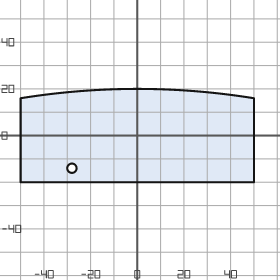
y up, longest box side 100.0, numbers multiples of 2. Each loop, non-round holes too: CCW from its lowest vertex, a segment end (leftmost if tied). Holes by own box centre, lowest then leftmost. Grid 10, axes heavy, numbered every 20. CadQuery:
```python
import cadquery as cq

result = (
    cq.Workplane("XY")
    .moveTo(-50.0, -20.0)
    .lineTo(50.0, -20.0)
    .lineTo(50.0, 16.0)
    .threePointArc((0.0, 20.0), (-50.0, 16.0))
    .close()
    .moveTo(-28.0, -14.0)
    .circle(2.0)
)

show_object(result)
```